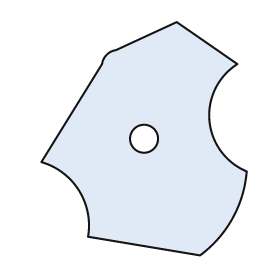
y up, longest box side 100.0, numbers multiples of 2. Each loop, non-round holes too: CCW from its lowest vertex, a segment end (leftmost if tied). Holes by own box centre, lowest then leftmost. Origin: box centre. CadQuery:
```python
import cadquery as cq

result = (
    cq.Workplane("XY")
    .moveTo(24.0, -50.0)
    .threePointArc((38.0, -34.0), (44.0, -14.0))
    .threePointArc((28.0, 8.0), (40.0, 32.0))
    .lineTo(14.0, 50.0)
    .lineTo(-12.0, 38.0)
    .threePointArc((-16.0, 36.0), (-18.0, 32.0))
    .lineTo(-44.0, -10.0)
    .threePointArc((-28.0, -22.0), (-24.0, -42.0))
    .close()
    .moveTo(0.0, 0.0)
    .circle(6.0)
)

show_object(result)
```